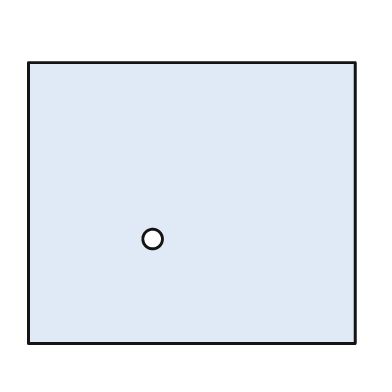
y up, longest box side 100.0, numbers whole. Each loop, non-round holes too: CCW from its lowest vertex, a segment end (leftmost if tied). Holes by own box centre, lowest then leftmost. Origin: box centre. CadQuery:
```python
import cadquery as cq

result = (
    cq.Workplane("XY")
    .moveTo(-50.0, -43.0)
    .lineTo(50.0, -43.0)
    .lineTo(50.0, 43.0)
    .lineTo(-50.0, 43.0)
    .close()
    .moveTo(-12.0, -11.0)
    .circle(3.0)
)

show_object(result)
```